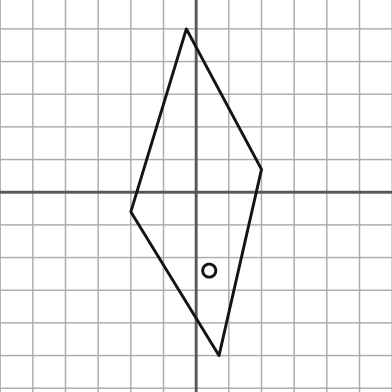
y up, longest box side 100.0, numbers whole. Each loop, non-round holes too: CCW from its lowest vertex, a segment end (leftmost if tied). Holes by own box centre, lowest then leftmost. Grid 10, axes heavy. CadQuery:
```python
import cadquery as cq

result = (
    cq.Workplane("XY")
    .moveTo(7.0, -50.0)
    .lineTo(20.0, 7.0)
    .lineTo(-3.0, 50.0)
    .lineTo(-20.0, -6.0)
    .close()
    .moveTo(4.0, -24.0)
    .circle(2.0)
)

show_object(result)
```